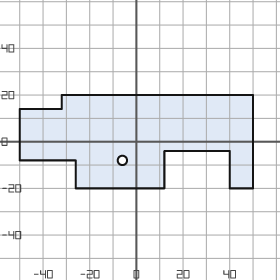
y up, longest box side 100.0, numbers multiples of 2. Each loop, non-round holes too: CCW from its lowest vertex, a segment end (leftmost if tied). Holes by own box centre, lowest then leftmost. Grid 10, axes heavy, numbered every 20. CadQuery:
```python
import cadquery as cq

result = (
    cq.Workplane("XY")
    .moveTo(-26.0, -20.0)
    .lineTo(12.0, -20.0)
    .lineTo(12.0, -4.0)
    .lineTo(40.0, -4.0)
    .lineTo(40.0, -20.0)
    .lineTo(50.0, -20.0)
    .lineTo(50.0, 20.0)
    .lineTo(-32.0, 20.0)
    .lineTo(-32.0, 14.0)
    .lineTo(-50.0, 14.0)
    .lineTo(-50.0, -8.0)
    .lineTo(-26.0, -8.0)
    .close()
    .moveTo(-6.0, -8.0)
    .circle(2.0)
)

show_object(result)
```